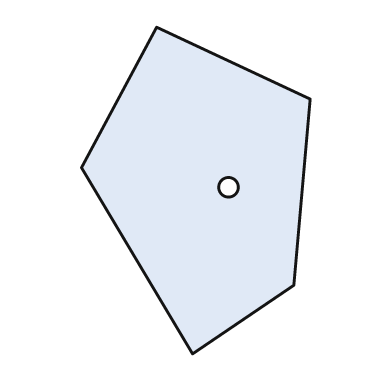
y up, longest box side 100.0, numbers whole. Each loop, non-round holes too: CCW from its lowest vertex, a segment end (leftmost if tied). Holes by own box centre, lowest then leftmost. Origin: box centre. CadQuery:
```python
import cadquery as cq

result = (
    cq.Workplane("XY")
    .moveTo(-1.0, -50.0)
    .lineTo(30.0, -29.0)
    .lineTo(35.0, 28.0)
    .lineTo(-12.0, 50.0)
    .lineTo(-35.0, 7.0)
    .close()
    .moveTo(10.0, 1.0)
    .circle(3.0)
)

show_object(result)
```